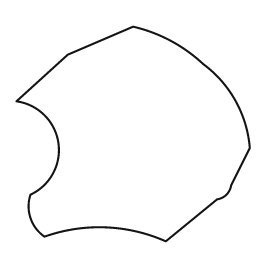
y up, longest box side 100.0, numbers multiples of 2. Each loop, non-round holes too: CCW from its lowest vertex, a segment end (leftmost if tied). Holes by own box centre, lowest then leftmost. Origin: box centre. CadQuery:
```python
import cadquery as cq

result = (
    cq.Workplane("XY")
    .moveTo(14.0, -46.0)
    .lineTo(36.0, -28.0)
    .threePointArc((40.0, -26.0), (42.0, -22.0))
    .lineTo(50.0, -6.0)
    .threePointArc((44.0, 14.0), (30.0, 30.0))
    .threePointArc((16.0, 40.0), (0.0, 46.0))
    .lineTo(-28.0, 34.0)
    .lineTo(-50.0, 14.0)
    .threePointArc((-32.0, -4.0), (-44.0, -26.0))
    .threePointArc((-44.0, -36.0), (-38.0, -44.0))
    .threePointArc((-12.0, -40.0), (14.0, -46.0))
    .close()
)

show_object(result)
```